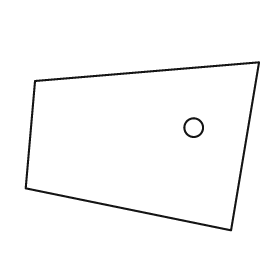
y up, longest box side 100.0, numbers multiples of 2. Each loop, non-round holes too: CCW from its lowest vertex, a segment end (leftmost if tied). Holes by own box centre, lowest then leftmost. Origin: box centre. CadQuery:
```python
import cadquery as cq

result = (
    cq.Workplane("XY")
    .moveTo(38.0, -36.0)
    .lineTo(50.0, 36.0)
    .lineTo(-46.0, 28.0)
    .lineTo(-50.0, -18.0)
    .close()
    .moveTo(22.0, 8.0)
    .circle(4.0)
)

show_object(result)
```